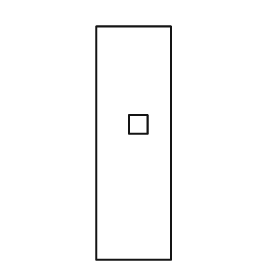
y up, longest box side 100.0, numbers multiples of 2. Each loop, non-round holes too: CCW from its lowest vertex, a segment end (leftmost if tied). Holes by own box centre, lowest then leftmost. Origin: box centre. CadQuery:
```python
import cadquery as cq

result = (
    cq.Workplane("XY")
    .moveTo(-16.0, -50.0)
    .lineTo(16.0, -50.0)
    .lineTo(16.0, 50.0)
    .lineTo(-16.0, 50.0)
    .close()
    .moveTo(-2.0, 4.0)
    .lineTo(6.0, 4.0)
    .lineTo(6.0, 12.0)
    .lineTo(-2.0, 12.0)
    .close()
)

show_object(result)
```